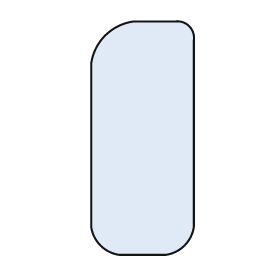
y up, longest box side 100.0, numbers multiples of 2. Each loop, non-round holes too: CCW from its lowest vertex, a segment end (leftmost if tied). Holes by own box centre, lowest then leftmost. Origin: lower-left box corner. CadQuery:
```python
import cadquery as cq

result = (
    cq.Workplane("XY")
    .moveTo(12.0, 0.0)
    .lineTo(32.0, 0.0)
    .threePointArc((40.0, 4.0), (44.0, 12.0))
    .lineTo(44.0, 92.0)
    .threePointArc((42.0, 98.0), (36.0, 100.0))
    .lineTo(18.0, 100.0)
    .threePointArc((6.0, 94.0), (0.0, 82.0))
    .lineTo(0.0, 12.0)
    .threePointArc((4.0, 4.0), (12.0, 0.0))
    .close()
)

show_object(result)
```